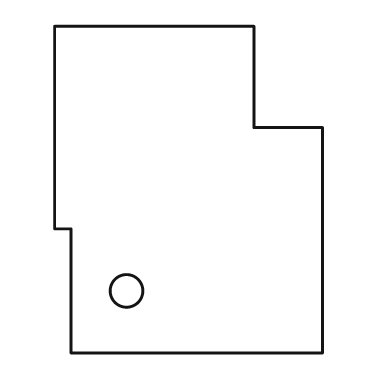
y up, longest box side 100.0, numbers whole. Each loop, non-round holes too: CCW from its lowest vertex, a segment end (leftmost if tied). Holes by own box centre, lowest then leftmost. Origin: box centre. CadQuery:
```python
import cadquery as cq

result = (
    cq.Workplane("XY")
    .moveTo(-36.0, -50.0)
    .lineTo(41.0, -50.0)
    .lineTo(41.0, 19.0)
    .lineTo(20.0, 19.0)
    .lineTo(20.0, 50.0)
    .lineTo(-41.0, 50.0)
    .lineTo(-41.0, -12.0)
    .lineTo(-36.0, -12.0)
    .close()
    .moveTo(-19.0, -31.0)
    .circle(5.0)
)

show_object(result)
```